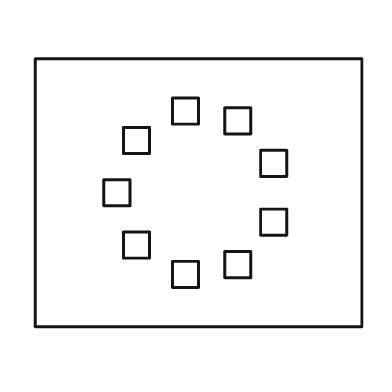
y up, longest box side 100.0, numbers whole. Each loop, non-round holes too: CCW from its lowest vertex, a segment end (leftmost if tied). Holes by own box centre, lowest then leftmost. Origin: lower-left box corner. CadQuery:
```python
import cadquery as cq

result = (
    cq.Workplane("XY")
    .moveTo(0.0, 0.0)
    .lineTo(100.0, 0.0)
    .lineTo(100.0, 82.0)
    .lineTo(0.0, 82.0)
    .close()
    .moveTo(42.0, 12.0)
    .lineTo(50.0, 12.0)
    .lineTo(50.0, 20.0)
    .lineTo(42.0, 20.0)
    .close()
    .moveTo(58.0, 15.0)
    .lineTo(66.0, 15.0)
    .lineTo(66.0, 23.0)
    .lineTo(58.0, 23.0)
    .close()
    .moveTo(27.0, 21.0)
    .lineTo(35.0, 21.0)
    .lineTo(35.0, 29.0)
    .lineTo(27.0, 29.0)
    .close()
    .moveTo(69.0, 28.0)
    .lineTo(77.0, 28.0)
    .lineTo(77.0, 36.0)
    .lineTo(69.0, 36.0)
    .close()
    .moveTo(21.0, 37.0)
    .lineTo(29.0, 37.0)
    .lineTo(29.0, 45.0)
    .lineTo(21.0, 45.0)
    .close()
    .moveTo(69.0, 46.0)
    .lineTo(77.0, 46.0)
    .lineTo(77.0, 54.0)
    .lineTo(69.0, 54.0)
    .close()
    .moveTo(27.0, 53.0)
    .lineTo(35.0, 53.0)
    .lineTo(35.0, 61.0)
    .lineTo(27.0, 61.0)
    .close()
    .moveTo(58.0, 59.0)
    .lineTo(66.0, 59.0)
    .lineTo(66.0, 67.0)
    .lineTo(58.0, 67.0)
    .close()
    .moveTo(42.0, 62.0)
    .lineTo(50.0, 62.0)
    .lineTo(50.0, 70.0)
    .lineTo(42.0, 70.0)
    .close()
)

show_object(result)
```